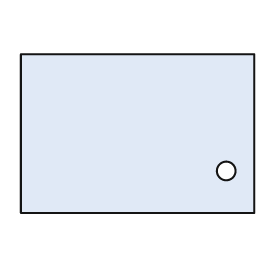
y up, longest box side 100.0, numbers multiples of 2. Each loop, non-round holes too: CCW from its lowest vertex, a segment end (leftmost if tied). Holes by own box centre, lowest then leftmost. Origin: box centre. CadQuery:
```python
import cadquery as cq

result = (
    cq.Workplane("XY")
    .moveTo(-50.0, -34.0)
    .lineTo(50.0, -34.0)
    .lineTo(50.0, 34.0)
    .lineTo(-50.0, 34.0)
    .close()
    .moveTo(38.0, -16.0)
    .circle(4.0)
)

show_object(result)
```